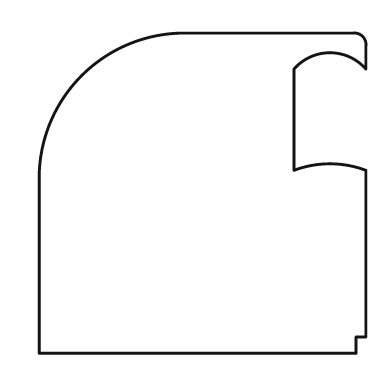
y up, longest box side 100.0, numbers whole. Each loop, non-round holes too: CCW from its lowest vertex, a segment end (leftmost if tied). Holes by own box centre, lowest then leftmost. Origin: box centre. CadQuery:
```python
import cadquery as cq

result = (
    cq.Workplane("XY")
    .moveTo(-50.0, -49.0)
    .lineTo(47.0, -49.0)
    .lineTo(47.0, -44.0)
    .lineTo(50.0, -44.0)
    .lineTo(50.0, 7.0)
    .threePointArc((39.0, 9.0), (28.0, 7.0))
    .lineTo(28.0, 38.0)
    .threePointArc((39.0, 43.0), (50.0, 38.0))
    .lineTo(50.0, 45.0)
    .threePointArc((49.0, 48.0), (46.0, 49.0))
    .lineTo(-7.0, 49.0)
    .threePointArc((-37.0, 36.0), (-50.0, 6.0))
    .close()
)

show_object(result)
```